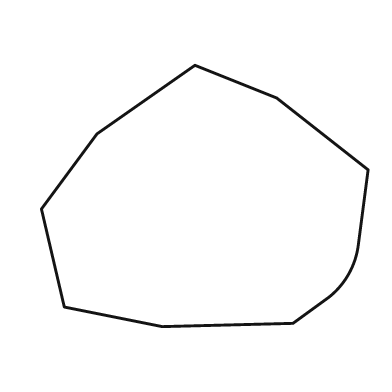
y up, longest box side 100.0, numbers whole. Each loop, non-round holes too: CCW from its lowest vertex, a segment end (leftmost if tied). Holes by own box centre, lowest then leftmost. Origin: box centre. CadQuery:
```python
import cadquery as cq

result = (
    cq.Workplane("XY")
    .moveTo(-13.0, -40.0)
    .lineTo(27.0, -39.0)
    .lineTo(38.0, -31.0)
    .threePointArc((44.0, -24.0), (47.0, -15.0))
    .lineTo(50.0, 8.0)
    .lineTo(22.0, 30.0)
    .lineTo(-3.0, 40.0)
    .lineTo(-33.0, 19.0)
    .lineTo(-50.0, -4.0)
    .lineTo(-43.0, -34.0)
    .close()
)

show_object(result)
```